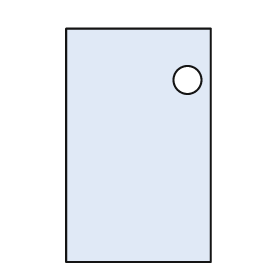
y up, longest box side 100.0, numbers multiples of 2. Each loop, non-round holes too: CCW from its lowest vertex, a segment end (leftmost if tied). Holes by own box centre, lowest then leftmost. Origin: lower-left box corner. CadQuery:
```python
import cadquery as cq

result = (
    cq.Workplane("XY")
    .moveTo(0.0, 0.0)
    .lineTo(62.0, 0.0)
    .lineTo(62.0, 100.0)
    .lineTo(0.0, 100.0)
    .close()
    .moveTo(52.0, 78.0)
    .circle(6.0)
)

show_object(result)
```